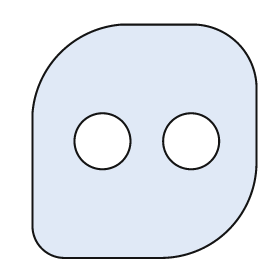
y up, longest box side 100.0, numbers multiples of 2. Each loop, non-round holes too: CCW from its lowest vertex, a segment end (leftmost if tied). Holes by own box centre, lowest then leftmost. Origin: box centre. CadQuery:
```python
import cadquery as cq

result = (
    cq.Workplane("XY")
    .moveTo(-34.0, -50.0)
    .lineTo(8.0, -50.0)
    .threePointArc((36.0, -38.0), (48.0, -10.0))
    .lineTo(48.0, 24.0)
    .threePointArc((40.0, 42.0), (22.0, 50.0))
    .lineTo(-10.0, 50.0)
    .threePointArc((-36.0, 38.0), (-48.0, 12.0))
    .lineTo(-48.0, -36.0)
    .threePointArc((-44.0, -46.0), (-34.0, -50.0))
    .close()
    .moveTo(-18.0, 0.0)
    .circle(12.0)
    .moveTo(20.0, 0.0)
    .circle(12.0)
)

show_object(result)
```